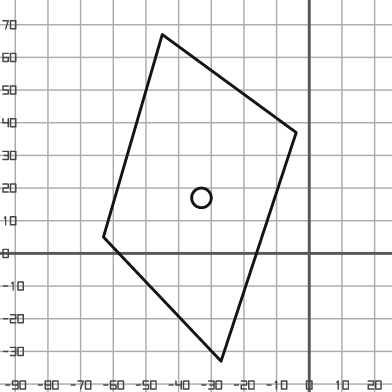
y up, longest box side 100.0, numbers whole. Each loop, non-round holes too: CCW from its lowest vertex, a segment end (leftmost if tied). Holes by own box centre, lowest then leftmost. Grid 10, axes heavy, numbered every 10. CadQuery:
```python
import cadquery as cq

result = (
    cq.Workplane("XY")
    .moveTo(-27.0, -33.0)
    .lineTo(-4.0, 37.0)
    .lineTo(-45.0, 67.0)
    .lineTo(-63.0, 5.0)
    .close()
    .moveTo(-33.0, 17.0)
    .circle(3.0)
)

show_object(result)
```